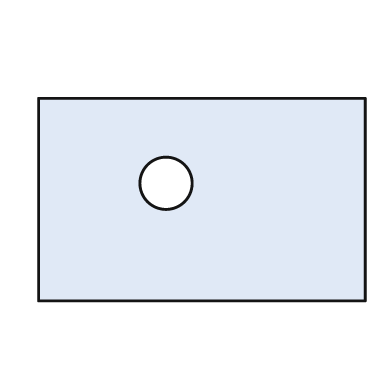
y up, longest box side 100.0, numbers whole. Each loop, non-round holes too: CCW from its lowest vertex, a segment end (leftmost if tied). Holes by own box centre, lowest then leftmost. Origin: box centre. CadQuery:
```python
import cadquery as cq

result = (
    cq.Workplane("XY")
    .moveTo(-50.0, -31.0)
    .lineTo(50.0, -31.0)
    .lineTo(50.0, 31.0)
    .lineTo(-50.0, 31.0)
    .close()
    .moveTo(-11.0, 5.0)
    .circle(8.0)
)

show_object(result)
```